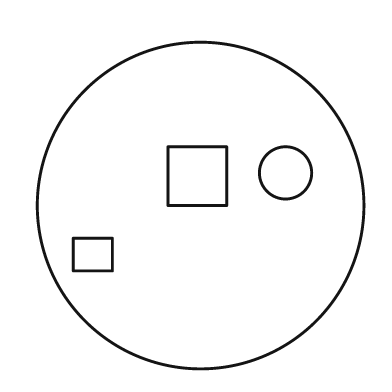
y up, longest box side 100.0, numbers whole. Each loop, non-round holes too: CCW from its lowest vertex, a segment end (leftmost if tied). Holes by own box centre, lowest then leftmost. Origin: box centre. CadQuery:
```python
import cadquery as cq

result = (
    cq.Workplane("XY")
    .moveTo(0.0, 0.0)
    .circle(50.0)
    .moveTo(-39.0, -20.0)
    .lineTo(-27.0, -20.0)
    .lineTo(-27.0, -10.0)
    .lineTo(-39.0, -10.0)
    .close()
    .moveTo(-10.0, 0.0)
    .lineTo(8.0, 0.0)
    .lineTo(8.0, 18.0)
    .lineTo(-10.0, 18.0)
    .close()
    .moveTo(26.0, 10.0)
    .circle(8.0)
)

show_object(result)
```